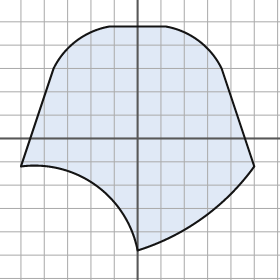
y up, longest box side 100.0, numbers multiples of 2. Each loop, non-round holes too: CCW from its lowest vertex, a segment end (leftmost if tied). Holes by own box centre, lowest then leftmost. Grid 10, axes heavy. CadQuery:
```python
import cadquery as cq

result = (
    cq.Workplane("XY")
    .moveTo(0.0, -48.0)
    .threePointArc((28.0, -34.0), (50.0, -12.0))
    .lineTo(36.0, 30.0)
    .threePointArc((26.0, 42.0), (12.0, 48.0))
    .lineTo(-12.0, 48.0)
    .threePointArc((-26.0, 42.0), (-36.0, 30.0))
    .lineTo(-50.0, -12.0)
    .threePointArc((-18.0, -20.0), (0.0, -48.0))
    .close()
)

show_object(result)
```